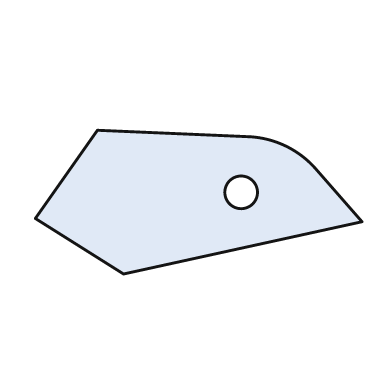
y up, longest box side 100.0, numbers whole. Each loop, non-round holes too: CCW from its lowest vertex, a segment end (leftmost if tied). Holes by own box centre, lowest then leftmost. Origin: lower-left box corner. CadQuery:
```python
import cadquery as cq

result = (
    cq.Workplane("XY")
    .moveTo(27.0, 0.0)
    .lineTo(100.0, 16.0)
    .lineTo(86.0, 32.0)
    .threePointArc((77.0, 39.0), (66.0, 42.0))
    .lineTo(19.0, 44.0)
    .lineTo(0.0, 17.0)
    .close()
    .moveTo(63.0, 25.0)
    .circle(5.0)
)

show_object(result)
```